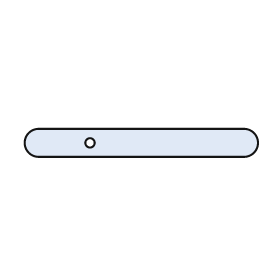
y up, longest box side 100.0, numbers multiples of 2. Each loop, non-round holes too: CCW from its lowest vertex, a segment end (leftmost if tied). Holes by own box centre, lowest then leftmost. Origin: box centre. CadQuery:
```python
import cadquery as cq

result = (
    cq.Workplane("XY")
    .moveTo(-44.0, -6.0)
    .lineTo(44.0, -6.0)
    .threePointArc((50.0, 0.0), (44.0, 6.0))
    .lineTo(-44.0, 6.0)
    .threePointArc((-50.0, 0.0), (-44.0, -6.0))
    .close()
    .moveTo(-22.0, 0.0)
    .circle(2.0)
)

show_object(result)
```